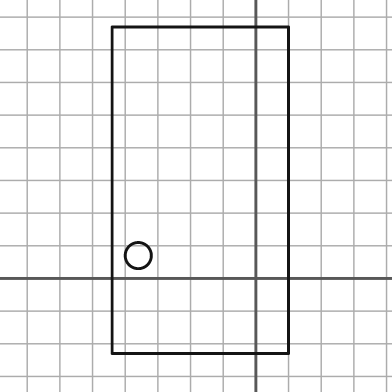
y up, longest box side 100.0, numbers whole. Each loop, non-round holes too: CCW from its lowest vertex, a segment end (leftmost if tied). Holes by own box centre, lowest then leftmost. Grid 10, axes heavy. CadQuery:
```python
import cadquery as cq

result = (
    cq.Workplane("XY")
    .moveTo(-44.0, -23.0)
    .lineTo(10.0, -23.0)
    .lineTo(10.0, 77.0)
    .lineTo(-44.0, 77.0)
    .close()
    .moveTo(-36.0, 7.0)
    .circle(4.0)
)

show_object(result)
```